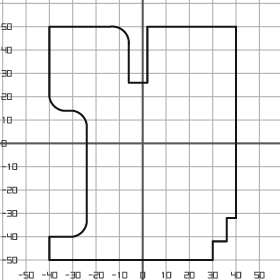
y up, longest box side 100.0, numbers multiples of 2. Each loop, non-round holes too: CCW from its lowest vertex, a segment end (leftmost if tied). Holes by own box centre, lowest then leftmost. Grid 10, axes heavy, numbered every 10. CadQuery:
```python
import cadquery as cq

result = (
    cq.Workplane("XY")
    .moveTo(-40.0, -50.0)
    .lineTo(30.0, -50.0)
    .lineTo(30.0, -42.0)
    .lineTo(36.0, -42.0)
    .lineTo(36.0, -32.0)
    .lineTo(40.0, -32.0)
    .lineTo(40.0, 50.0)
    .lineTo(2.0, 50.0)
    .lineTo(2.0, 26.0)
    .lineTo(-6.0, 26.0)
    .lineTo(-6.0, 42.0)
    .threePointArc((-8.0, 48.0), (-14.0, 50.0))
    .lineTo(-40.0, 50.0)
    .lineTo(-40.0, 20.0)
    .threePointArc((-38.0, 16.0), (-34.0, 14.0))
    .lineTo(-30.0, 14.0)
    .threePointArc((-26.0, 12.0), (-24.0, 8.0))
    .lineTo(-24.0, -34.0)
    .threePointArc((-26.0, -38.0), (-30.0, -40.0))
    .lineTo(-40.0, -40.0)
    .close()
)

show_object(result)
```